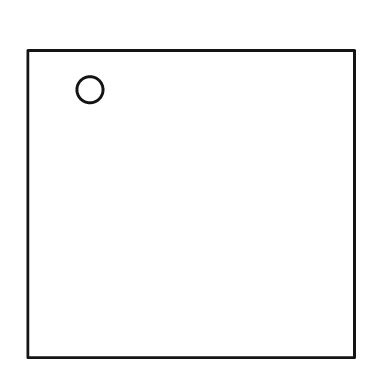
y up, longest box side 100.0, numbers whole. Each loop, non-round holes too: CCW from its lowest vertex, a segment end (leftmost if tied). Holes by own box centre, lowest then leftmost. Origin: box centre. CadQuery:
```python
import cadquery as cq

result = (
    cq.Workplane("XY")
    .moveTo(-50.0, -47.0)
    .lineTo(50.0, -47.0)
    .lineTo(50.0, 47.0)
    .lineTo(-50.0, 47.0)
    .close()
    .moveTo(-31.0, 35.0)
    .circle(4.0)
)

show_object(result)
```